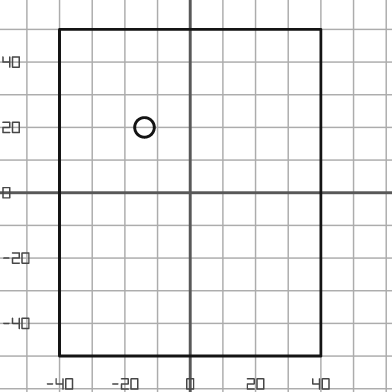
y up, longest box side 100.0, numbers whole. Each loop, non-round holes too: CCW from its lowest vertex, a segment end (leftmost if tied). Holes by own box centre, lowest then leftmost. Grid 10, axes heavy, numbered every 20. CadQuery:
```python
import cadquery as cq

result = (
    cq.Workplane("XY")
    .moveTo(-40.0, -50.0)
    .lineTo(40.0, -50.0)
    .lineTo(40.0, 50.0)
    .lineTo(-40.0, 50.0)
    .close()
    .moveTo(-14.0, 20.0)
    .circle(3.0)
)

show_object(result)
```